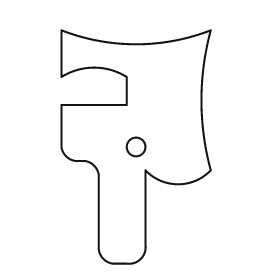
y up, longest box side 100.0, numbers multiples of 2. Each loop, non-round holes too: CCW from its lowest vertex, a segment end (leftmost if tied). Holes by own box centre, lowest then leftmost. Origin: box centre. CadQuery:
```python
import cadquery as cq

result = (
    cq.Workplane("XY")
    .moveTo(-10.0, -50.0)
    .lineTo(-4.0, -50.0)
    .threePointArc((2.0, -48.0), (4.0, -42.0))
    .lineTo(4.0, -10.0)
    .threePointArc((18.0, -16.0), (32.0, -10.0))
    .threePointArc((28.0, 20.0), (32.0, 50.0))
    .threePointArc((0.0, 44.0), (-32.0, 50.0))
    .lineTo(-32.0, 30.0)
    .threePointArc((-18.0, 34.0), (-4.0, 30.0))
    .lineTo(-4.0, 18.0)
    .lineTo(-32.0, 18.0)
    .lineTo(-32.0, 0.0)
    .threePointArc((-30.0, -4.0), (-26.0, -6.0))
    .lineTo(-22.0, -6.0)
    .threePointArc((-18.0, -8.0), (-16.0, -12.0))
    .lineTo(-16.0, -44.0)
    .threePointArc((-14.0, -48.0), (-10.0, -50.0))
    .close()
    .moveTo(0.0, 0.0)
    .circle(4.0)
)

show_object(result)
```